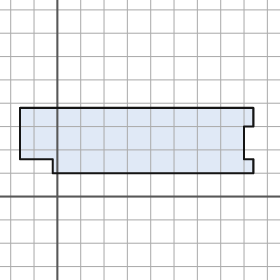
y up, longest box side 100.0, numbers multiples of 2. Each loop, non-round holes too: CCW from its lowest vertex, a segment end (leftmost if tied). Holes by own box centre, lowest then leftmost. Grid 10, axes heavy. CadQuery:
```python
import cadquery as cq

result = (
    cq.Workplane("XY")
    .moveTo(-2.0, 10.0)
    .lineTo(84.0, 10.0)
    .lineTo(84.0, 16.0)
    .lineTo(80.0, 16.0)
    .lineTo(80.0, 30.0)
    .lineTo(84.0, 30.0)
    .lineTo(84.0, 38.0)
    .lineTo(-16.0, 38.0)
    .lineTo(-16.0, 16.0)
    .lineTo(-2.0, 16.0)
    .close()
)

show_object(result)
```